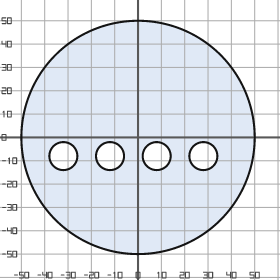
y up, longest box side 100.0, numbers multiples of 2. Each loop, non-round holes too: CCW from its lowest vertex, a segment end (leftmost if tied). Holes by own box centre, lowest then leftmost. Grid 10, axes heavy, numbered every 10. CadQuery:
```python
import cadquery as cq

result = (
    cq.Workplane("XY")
    .moveTo(0.0, 0.0)
    .circle(50.0)
    .moveTo(-32.0, -8.0)
    .circle(6.0)
    .moveTo(-12.0, -8.0)
    .circle(6.0)
    .moveTo(8.0, -8.0)
    .circle(6.0)
    .moveTo(28.0, -8.0)
    .circle(6.0)
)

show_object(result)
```